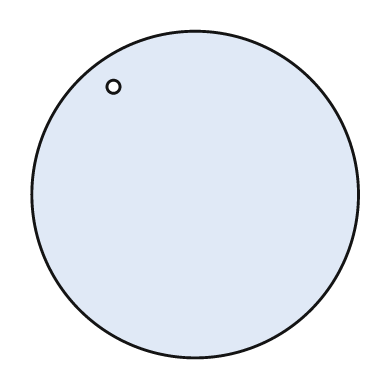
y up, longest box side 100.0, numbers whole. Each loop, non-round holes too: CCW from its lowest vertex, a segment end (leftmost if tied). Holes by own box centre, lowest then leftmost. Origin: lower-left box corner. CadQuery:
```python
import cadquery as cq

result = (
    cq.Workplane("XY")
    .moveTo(50.0, 50.0)
    .circle(50.0)
    .moveTo(25.0, 83.0)
    .circle(2.0)
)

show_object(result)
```